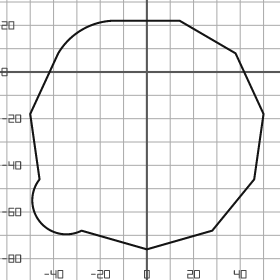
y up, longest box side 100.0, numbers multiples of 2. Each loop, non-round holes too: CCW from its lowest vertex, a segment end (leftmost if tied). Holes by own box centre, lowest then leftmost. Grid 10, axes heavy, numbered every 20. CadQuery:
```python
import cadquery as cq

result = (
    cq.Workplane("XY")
    .moveTo(0.0, -76.0)
    .lineTo(28.0, -68.0)
    .lineTo(46.0, -46.0)
    .lineTo(50.0, -18.0)
    .lineTo(38.0, 8.0)
    .lineTo(14.0, 22.0)
    .lineTo(-14.0, 22.0)
    .threePointArc((-28.0, 18.0), (-38.0, 8.0))
    .lineTo(-50.0, -18.0)
    .lineTo(-46.0, -46.0)
    .threePointArc((-46.0, -64.0), (-28.0, -68.0))
    .close()
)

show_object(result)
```